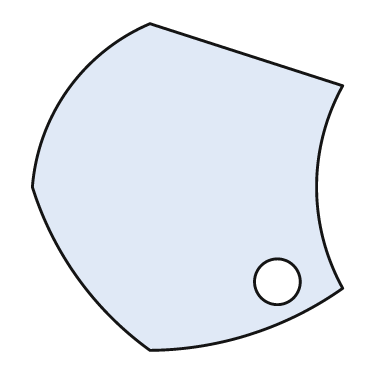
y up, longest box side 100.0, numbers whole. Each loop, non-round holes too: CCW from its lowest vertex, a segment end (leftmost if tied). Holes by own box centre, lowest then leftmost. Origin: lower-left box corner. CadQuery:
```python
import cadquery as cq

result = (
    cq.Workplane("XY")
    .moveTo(36.0, 0.0)
    .threePointArc((67.0, 5.0), (95.0, 19.0))
    .threePointArc((87.0, 50.0), (95.0, 81.0))
    .lineTo(36.0, 100.0)
    .threePointArc((11.0, 80.0), (0.0, 50.0))
    .threePointArc((14.0, 22.0), (36.0, 0.0))
    .close()
    .moveTo(75.0, 21.0)
    .circle(7.0)
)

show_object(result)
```